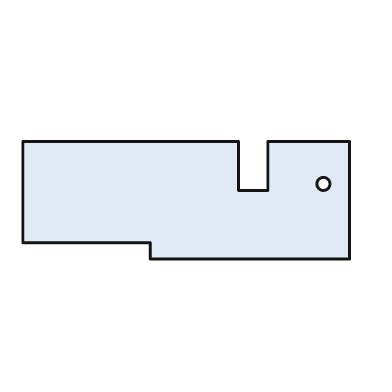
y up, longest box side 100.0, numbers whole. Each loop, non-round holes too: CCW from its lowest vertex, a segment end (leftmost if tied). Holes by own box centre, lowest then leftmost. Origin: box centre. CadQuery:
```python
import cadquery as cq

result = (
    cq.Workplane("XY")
    .moveTo(-11.0, -18.0)
    .lineTo(50.0, -18.0)
    .lineTo(50.0, 18.0)
    .lineTo(25.0, 18.0)
    .lineTo(25.0, 3.0)
    .lineTo(16.0, 3.0)
    .lineTo(16.0, 18.0)
    .lineTo(-50.0, 18.0)
    .lineTo(-50.0, -13.0)
    .lineTo(-11.0, -13.0)
    .close()
    .moveTo(42.0, 5.0)
    .circle(2.0)
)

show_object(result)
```